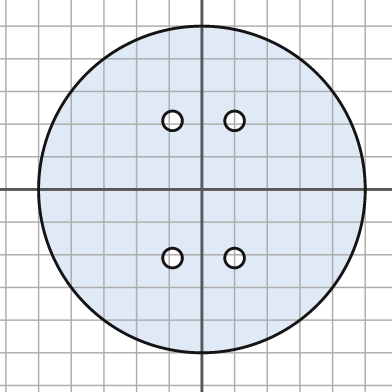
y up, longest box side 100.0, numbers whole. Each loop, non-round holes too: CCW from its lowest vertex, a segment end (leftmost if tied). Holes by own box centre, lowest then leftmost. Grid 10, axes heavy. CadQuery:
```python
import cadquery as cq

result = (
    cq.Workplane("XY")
    .moveTo(0.0, 0.0)
    .circle(50.0)
    .moveTo(-9.0, -21.0)
    .circle(3.0)
    .moveTo(10.0, -21.0)
    .circle(3.0)
    .moveTo(-9.0, 21.0)
    .circle(3.0)
    .moveTo(10.0, 21.0)
    .circle(3.0)
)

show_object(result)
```